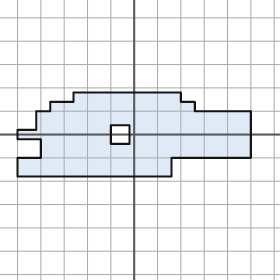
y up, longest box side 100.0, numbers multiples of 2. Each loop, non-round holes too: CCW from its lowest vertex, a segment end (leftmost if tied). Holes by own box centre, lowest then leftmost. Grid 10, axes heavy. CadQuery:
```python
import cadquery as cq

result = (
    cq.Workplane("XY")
    .moveTo(-50.0, -18.0)
    .lineTo(16.0, -18.0)
    .lineTo(16.0, -10.0)
    .lineTo(50.0, -10.0)
    .lineTo(50.0, 10.0)
    .lineTo(26.0, 10.0)
    .lineTo(26.0, 14.0)
    .lineTo(20.0, 14.0)
    .lineTo(20.0, 18.0)
    .lineTo(-26.0, 18.0)
    .lineTo(-26.0, 14.0)
    .lineTo(-36.0, 14.0)
    .lineTo(-36.0, 10.0)
    .lineTo(-42.0, 10.0)
    .lineTo(-42.0, 2.0)
    .lineTo(-50.0, 2.0)
    .lineTo(-50.0, -2.0)
    .lineTo(-40.0, -2.0)
    .lineTo(-40.0, -10.0)
    .lineTo(-50.0, -10.0)
    .close()
    .moveTo(-10.0, -4.0)
    .lineTo(-2.0, -4.0)
    .lineTo(-2.0, 4.0)
    .lineTo(-10.0, 4.0)
    .close()
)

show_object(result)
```